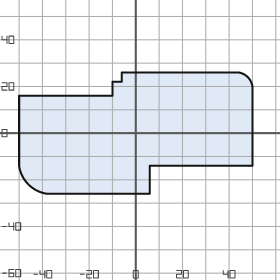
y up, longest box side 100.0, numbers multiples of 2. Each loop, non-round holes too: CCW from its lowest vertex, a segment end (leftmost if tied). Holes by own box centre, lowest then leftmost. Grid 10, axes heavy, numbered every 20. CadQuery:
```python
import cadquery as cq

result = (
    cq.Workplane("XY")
    .moveTo(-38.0, -26.0)
    .lineTo(6.0, -26.0)
    .lineTo(6.0, -14.0)
    .lineTo(50.0, -14.0)
    .lineTo(50.0, 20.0)
    .threePointArc((48.0, 24.0), (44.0, 26.0))
    .lineTo(-6.0, 26.0)
    .lineTo(-6.0, 22.0)
    .lineTo(-10.0, 22.0)
    .lineTo(-10.0, 16.0)
    .lineTo(-50.0, 16.0)
    .lineTo(-50.0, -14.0)
    .threePointArc((-46.0, -22.0), (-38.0, -26.0))
    .close()
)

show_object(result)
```